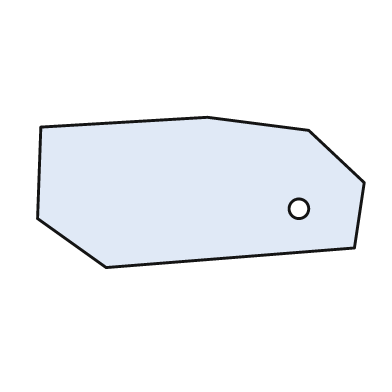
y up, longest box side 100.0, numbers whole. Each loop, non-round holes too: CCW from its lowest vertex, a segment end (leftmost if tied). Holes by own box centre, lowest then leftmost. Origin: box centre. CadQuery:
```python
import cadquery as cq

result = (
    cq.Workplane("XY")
    .moveTo(-29.0, -23.0)
    .lineTo(47.0, -17.0)
    .lineTo(50.0, 3.0)
    .lineTo(33.0, 19.0)
    .lineTo(2.0, 23.0)
    .lineTo(-49.0, 20.0)
    .lineTo(-50.0, -8.0)
    .close()
    .moveTo(30.0, -5.0)
    .circle(3.0)
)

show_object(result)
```